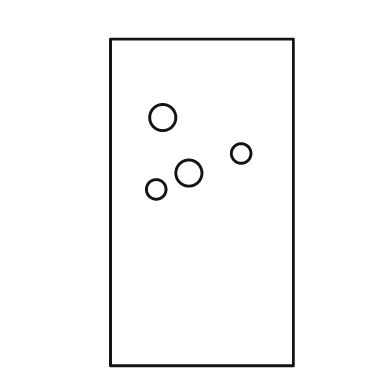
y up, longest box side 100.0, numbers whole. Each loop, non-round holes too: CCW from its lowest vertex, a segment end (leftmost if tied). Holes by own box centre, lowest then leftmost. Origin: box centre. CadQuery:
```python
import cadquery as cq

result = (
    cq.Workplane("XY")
    .moveTo(-28.0, -50.0)
    .lineTo(28.0, -50.0)
    .lineTo(28.0, 50.0)
    .lineTo(-28.0, 50.0)
    .close()
    .moveTo(-14.0, 4.0)
    .circle(3.0)
    .moveTo(-4.0, 9.0)
    .circle(4.0)
    .moveTo(12.0, 15.0)
    .circle(3.0)
    .moveTo(-12.0, 26.0)
    .circle(4.0)
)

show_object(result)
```